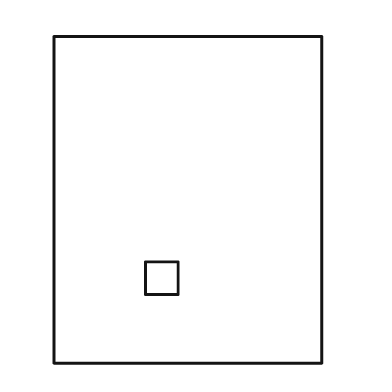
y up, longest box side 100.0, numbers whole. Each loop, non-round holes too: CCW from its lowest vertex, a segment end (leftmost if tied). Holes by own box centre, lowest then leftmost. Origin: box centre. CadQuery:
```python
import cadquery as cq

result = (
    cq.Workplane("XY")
    .moveTo(-41.0, -50.0)
    .lineTo(41.0, -50.0)
    .lineTo(41.0, 50.0)
    .lineTo(-41.0, 50.0)
    .close()
    .moveTo(-13.0, -29.0)
    .lineTo(-3.0, -29.0)
    .lineTo(-3.0, -19.0)
    .lineTo(-13.0, -19.0)
    .close()
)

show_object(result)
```